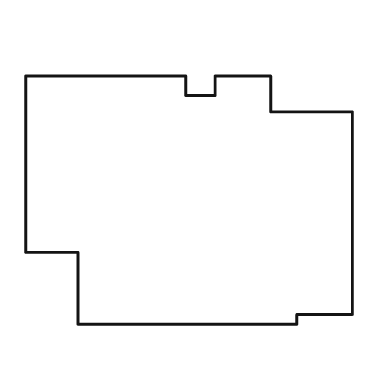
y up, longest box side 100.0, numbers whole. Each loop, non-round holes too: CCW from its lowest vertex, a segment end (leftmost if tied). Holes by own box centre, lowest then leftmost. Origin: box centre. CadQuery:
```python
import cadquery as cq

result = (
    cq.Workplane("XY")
    .moveTo(-34.0, -38.0)
    .lineTo(33.0, -38.0)
    .lineTo(33.0, -35.0)
    .lineTo(50.0, -35.0)
    .lineTo(50.0, 27.0)
    .lineTo(25.0, 27.0)
    .lineTo(25.0, 38.0)
    .lineTo(8.0, 38.0)
    .lineTo(8.0, 32.0)
    .lineTo(-1.0, 32.0)
    .lineTo(-1.0, 38.0)
    .lineTo(-50.0, 38.0)
    .lineTo(-50.0, -16.0)
    .lineTo(-34.0, -16.0)
    .close()
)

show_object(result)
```